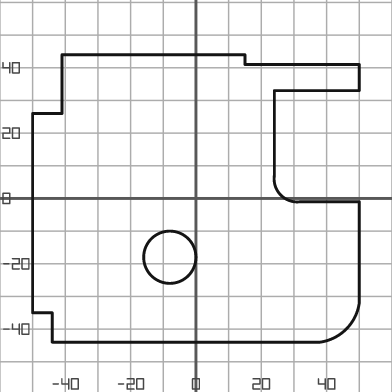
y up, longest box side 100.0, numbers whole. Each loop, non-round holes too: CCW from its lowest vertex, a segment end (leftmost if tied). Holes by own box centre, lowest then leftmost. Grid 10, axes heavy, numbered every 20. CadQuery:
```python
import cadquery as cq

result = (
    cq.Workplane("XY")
    .moveTo(-44.0, -44.0)
    .lineTo(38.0, -44.0)
    .threePointArc((46.0, -40.0), (50.0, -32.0))
    .lineTo(50.0, -1.0)
    .lineTo(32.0, -1.0)
    .threePointArc((26.0, 1.0), (24.0, 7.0))
    .lineTo(24.0, 33.0)
    .lineTo(50.0, 33.0)
    .lineTo(50.0, 41.0)
    .lineTo(15.0, 41.0)
    .lineTo(15.0, 44.0)
    .lineTo(-41.0, 44.0)
    .lineTo(-41.0, 26.0)
    .lineTo(-50.0, 26.0)
    .lineTo(-50.0, -35.0)
    .lineTo(-44.0, -35.0)
    .close()
    .moveTo(-8.0, -18.0)
    .circle(8.0)
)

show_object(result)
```